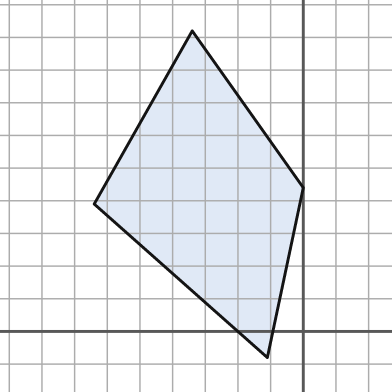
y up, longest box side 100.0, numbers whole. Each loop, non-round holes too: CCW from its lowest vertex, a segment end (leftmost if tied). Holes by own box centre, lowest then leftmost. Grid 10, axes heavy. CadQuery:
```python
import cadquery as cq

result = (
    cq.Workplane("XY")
    .moveTo(-11.0, -8.0)
    .lineTo(0.0, 44.0)
    .lineTo(-34.0, 92.0)
    .lineTo(-64.0, 39.0)
    .close()
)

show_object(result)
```